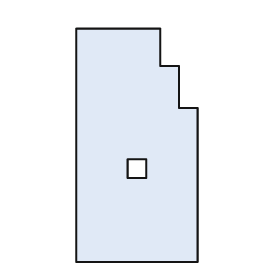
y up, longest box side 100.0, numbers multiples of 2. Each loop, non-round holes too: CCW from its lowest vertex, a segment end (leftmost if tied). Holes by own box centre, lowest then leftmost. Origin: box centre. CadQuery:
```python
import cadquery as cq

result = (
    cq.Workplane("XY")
    .moveTo(-26.0, -50.0)
    .lineTo(26.0, -50.0)
    .lineTo(26.0, 16.0)
    .lineTo(18.0, 16.0)
    .lineTo(18.0, 34.0)
    .lineTo(10.0, 34.0)
    .lineTo(10.0, 50.0)
    .lineTo(-26.0, 50.0)
    .close()
    .moveTo(-4.0, -14.0)
    .lineTo(4.0, -14.0)
    .lineTo(4.0, -6.0)
    .lineTo(-4.0, -6.0)
    .close()
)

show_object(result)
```